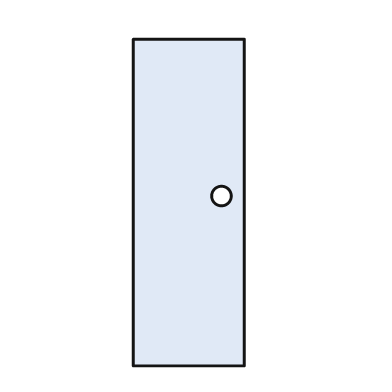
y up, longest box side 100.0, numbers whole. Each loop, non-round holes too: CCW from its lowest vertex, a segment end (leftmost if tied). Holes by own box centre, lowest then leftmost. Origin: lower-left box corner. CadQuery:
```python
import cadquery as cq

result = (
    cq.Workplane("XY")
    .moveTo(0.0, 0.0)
    .lineTo(34.0, 0.0)
    .lineTo(34.0, 100.0)
    .lineTo(0.0, 100.0)
    .close()
    .moveTo(27.0, 52.0)
    .circle(3.0)
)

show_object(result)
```